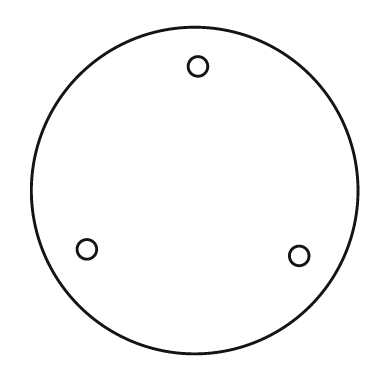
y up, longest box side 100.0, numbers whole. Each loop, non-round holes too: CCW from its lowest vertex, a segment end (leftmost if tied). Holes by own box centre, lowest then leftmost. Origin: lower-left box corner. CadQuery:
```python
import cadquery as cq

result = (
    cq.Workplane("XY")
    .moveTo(50.0, 50.0)
    .circle(50.0)
    .moveTo(82.0, 30.0)
    .circle(3.0)
    .moveTo(17.0, 32.0)
    .circle(3.0)
    .moveTo(51.0, 88.0)
    .circle(3.0)
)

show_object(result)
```